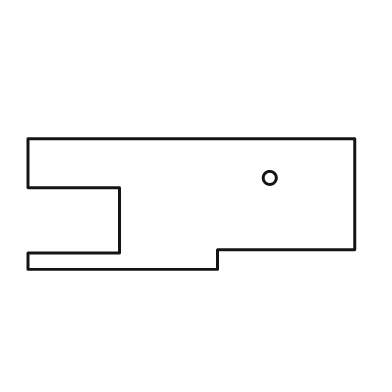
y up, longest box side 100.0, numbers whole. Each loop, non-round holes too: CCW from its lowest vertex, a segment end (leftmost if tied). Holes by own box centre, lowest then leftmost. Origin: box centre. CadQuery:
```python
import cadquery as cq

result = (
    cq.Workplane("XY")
    .moveTo(-50.0, -20.0)
    .lineTo(8.0, -20.0)
    .lineTo(8.0, -14.0)
    .lineTo(50.0, -14.0)
    .lineTo(50.0, 20.0)
    .lineTo(-50.0, 20.0)
    .lineTo(-50.0, 5.0)
    .lineTo(-22.0, 5.0)
    .lineTo(-22.0, -15.0)
    .lineTo(-50.0, -15.0)
    .close()
    .moveTo(24.0, 8.0)
    .circle(2.0)
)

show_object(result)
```